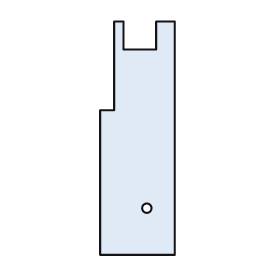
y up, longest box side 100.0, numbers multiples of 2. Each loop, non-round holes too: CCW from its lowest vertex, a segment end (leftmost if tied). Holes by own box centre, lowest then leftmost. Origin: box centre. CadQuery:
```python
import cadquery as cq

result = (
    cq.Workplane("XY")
    .moveTo(-16.0, -50.0)
    .lineTo(16.0, -50.0)
    .lineTo(16.0, 50.0)
    .lineTo(8.0, 50.0)
    .lineTo(8.0, 38.0)
    .lineTo(-6.0, 38.0)
    .lineTo(-6.0, 50.0)
    .lineTo(-10.0, 50.0)
    .lineTo(-10.0, 12.0)
    .lineTo(-16.0, 12.0)
    .close()
    .moveTo(4.0, -30.0)
    .circle(2.0)
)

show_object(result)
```